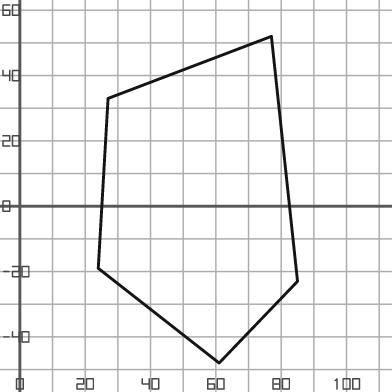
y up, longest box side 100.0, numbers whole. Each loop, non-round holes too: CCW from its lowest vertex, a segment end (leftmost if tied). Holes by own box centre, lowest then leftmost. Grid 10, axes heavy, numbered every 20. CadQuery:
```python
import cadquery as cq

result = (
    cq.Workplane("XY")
    .moveTo(61.0, -48.0)
    .lineTo(85.0, -23.0)
    .lineTo(77.0, 52.0)
    .lineTo(27.0, 33.0)
    .lineTo(24.0, -19.0)
    .close()
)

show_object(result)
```